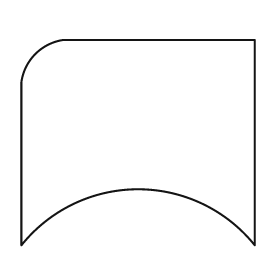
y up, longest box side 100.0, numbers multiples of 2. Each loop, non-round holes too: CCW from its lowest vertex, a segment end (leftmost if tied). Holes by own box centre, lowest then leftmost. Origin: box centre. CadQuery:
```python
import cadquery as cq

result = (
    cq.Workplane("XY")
    .moveTo(-50.0, -44.0)
    .threePointArc((0.0, -20.0), (50.0, -44.0))
    .lineTo(50.0, 44.0)
    .lineTo(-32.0, 44.0)
    .threePointArc((-44.0, 38.0), (-50.0, 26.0))
    .close()
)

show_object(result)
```